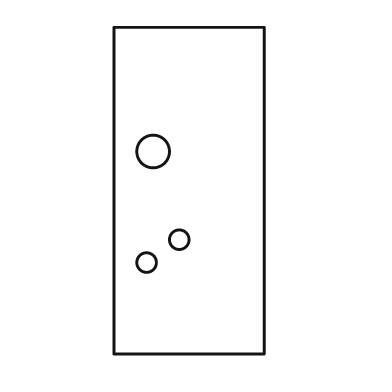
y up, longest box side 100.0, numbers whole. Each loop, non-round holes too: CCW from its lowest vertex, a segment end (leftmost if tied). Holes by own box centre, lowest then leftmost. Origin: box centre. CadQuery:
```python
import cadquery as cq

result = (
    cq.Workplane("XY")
    .moveTo(-23.0, -50.0)
    .lineTo(23.0, -50.0)
    .lineTo(23.0, 50.0)
    .lineTo(-23.0, 50.0)
    .close()
    .moveTo(-13.0, -22.0)
    .circle(3.0)
    .moveTo(-3.0, -15.0)
    .circle(3.0)
    .moveTo(-11.0, 12.0)
    .circle(5.0)
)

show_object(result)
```